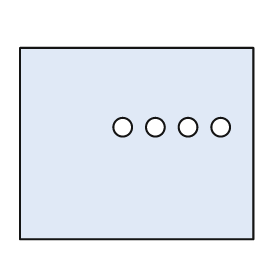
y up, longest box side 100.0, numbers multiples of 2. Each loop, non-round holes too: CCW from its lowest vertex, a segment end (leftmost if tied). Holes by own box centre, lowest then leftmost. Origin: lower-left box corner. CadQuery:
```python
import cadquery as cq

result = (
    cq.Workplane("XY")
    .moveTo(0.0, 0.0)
    .lineTo(100.0, 0.0)
    .lineTo(100.0, 82.0)
    .lineTo(0.0, 82.0)
    .close()
    .moveTo(44.0, 48.0)
    .circle(4.0)
    .moveTo(58.0, 48.0)
    .circle(4.0)
    .moveTo(72.0, 48.0)
    .circle(4.0)
    .moveTo(86.0, 48.0)
    .circle(4.0)
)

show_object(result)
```